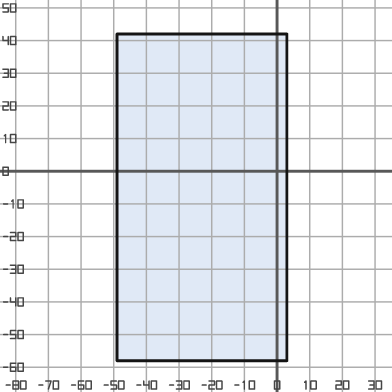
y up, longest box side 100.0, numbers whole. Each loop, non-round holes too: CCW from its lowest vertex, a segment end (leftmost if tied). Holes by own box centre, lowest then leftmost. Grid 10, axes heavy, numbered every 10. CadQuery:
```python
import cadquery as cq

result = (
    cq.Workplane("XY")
    .moveTo(-49.0, -58.0)
    .lineTo(3.0, -58.0)
    .lineTo(3.0, 42.0)
    .lineTo(-49.0, 42.0)
    .close()
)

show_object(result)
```